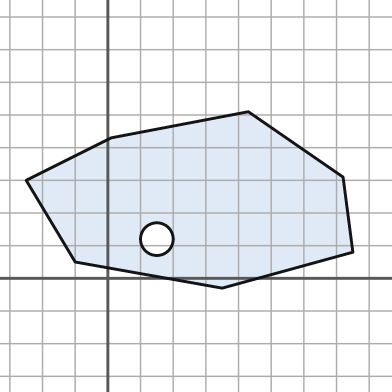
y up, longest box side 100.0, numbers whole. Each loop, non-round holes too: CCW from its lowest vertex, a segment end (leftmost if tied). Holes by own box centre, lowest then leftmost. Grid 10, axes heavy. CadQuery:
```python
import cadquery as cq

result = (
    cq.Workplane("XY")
    .moveTo(35.0, -3.0)
    .lineTo(75.0, 8.0)
    .lineTo(72.0, 31.0)
    .lineTo(43.0, 51.0)
    .lineTo(1.0, 43.0)
    .lineTo(-25.0, 30.0)
    .lineTo(-10.0, 5.0)
    .close()
    .moveTo(15.0, 12.0)
    .circle(5.0)
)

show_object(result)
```